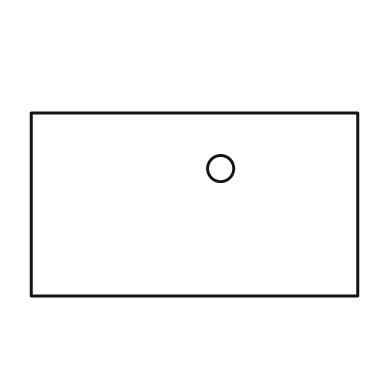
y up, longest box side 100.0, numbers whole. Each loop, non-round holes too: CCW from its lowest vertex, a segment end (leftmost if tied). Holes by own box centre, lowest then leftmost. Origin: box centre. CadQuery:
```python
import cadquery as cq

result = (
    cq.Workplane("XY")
    .moveTo(-50.0, -28.0)
    .lineTo(50.0, -28.0)
    .lineTo(50.0, 28.0)
    .lineTo(-50.0, 28.0)
    .close()
    .moveTo(8.0, 11.0)
    .circle(4.0)
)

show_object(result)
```